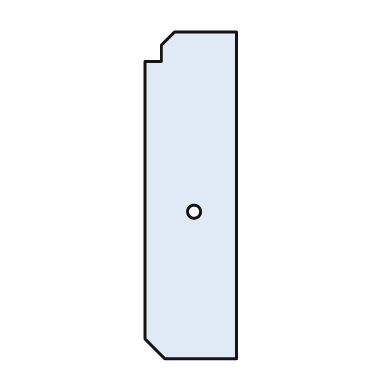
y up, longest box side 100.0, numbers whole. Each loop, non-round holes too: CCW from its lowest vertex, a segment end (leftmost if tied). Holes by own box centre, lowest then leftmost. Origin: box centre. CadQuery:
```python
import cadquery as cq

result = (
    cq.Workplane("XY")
    .moveTo(-8.0, -50.0)
    .lineTo(14.0, -50.0)
    .lineTo(14.0, 50.0)
    .lineTo(-5.0, 50.0)
    .lineTo(-9.0, 46.0)
    .lineTo(-9.0, 41.0)
    .lineTo(-14.0, 41.0)
    .lineTo(-14.0, -44.0)
    .close()
    .moveTo(1.0, -5.0)
    .circle(2.0)
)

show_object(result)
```